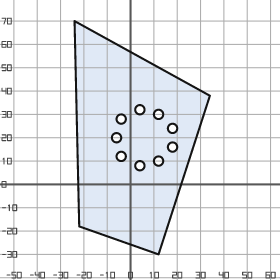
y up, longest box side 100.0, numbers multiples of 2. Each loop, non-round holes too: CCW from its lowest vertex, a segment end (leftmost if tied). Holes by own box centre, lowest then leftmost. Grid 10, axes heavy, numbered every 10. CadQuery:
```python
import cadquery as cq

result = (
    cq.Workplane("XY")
    .moveTo(12.0, -30.0)
    .lineTo(34.0, 38.0)
    .lineTo(-24.0, 70.0)
    .lineTo(-22.0, -18.0)
    .close()
    .moveTo(4.0, 8.0)
    .circle(2.0)
    .moveTo(12.0, 10.0)
    .circle(2.0)
    .moveTo(-4.0, 12.0)
    .circle(2.0)
    .moveTo(18.0, 16.0)
    .circle(2.0)
    .moveTo(-6.0, 20.0)
    .circle(2.0)
    .moveTo(18.0, 24.0)
    .circle(2.0)
    .moveTo(-4.0, 28.0)
    .circle(2.0)
    .moveTo(12.0, 30.0)
    .circle(2.0)
    .moveTo(4.0, 32.0)
    .circle(2.0)
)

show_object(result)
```